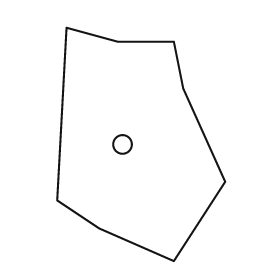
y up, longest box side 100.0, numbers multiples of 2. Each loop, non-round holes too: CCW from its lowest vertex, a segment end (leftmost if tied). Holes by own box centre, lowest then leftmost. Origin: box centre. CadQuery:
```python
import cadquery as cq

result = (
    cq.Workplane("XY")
    .moveTo(14.0, -50.0)
    .lineTo(36.0, -16.0)
    .lineTo(18.0, 24.0)
    .lineTo(14.0, 44.0)
    .lineTo(-10.0, 44.0)
    .lineTo(-32.0, 50.0)
    .lineTo(-36.0, -24.0)
    .lineTo(-18.0, -36.0)
    .close()
    .moveTo(-8.0, 0.0)
    .circle(4.0)
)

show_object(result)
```